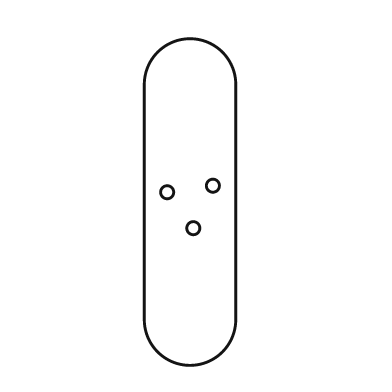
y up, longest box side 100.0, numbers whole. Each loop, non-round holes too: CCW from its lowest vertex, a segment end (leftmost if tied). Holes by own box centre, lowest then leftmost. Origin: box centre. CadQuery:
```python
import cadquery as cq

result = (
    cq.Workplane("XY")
    .moveTo(-14.0, -36.0)
    .threePointArc((0.0, -50.0), (14.0, -36.0))
    .lineTo(14.0, 36.0)
    .threePointArc((0.0, 50.0), (-14.0, 36.0))
    .close()
    .moveTo(1.0, -8.0)
    .circle(2.0)
    .moveTo(-7.0, 3.0)
    .circle(2.0)
    .moveTo(7.0, 5.0)
    .circle(2.0)
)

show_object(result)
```